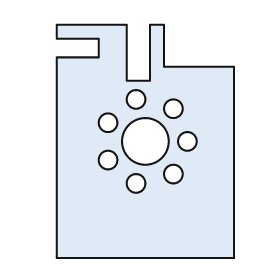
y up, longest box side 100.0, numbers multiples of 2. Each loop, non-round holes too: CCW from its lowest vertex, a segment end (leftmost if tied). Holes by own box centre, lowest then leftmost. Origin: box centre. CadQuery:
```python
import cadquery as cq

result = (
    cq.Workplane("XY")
    .moveTo(-38.0, -50.0)
    .lineTo(38.0, -50.0)
    .lineTo(38.0, 32.0)
    .lineTo(8.0, 32.0)
    .lineTo(8.0, 50.0)
    .lineTo(2.0, 50.0)
    .lineTo(2.0, 26.0)
    .lineTo(-8.0, 26.0)
    .lineTo(-8.0, 50.0)
    .lineTo(-38.0, 50.0)
    .lineTo(-38.0, 44.0)
    .lineTo(-20.0, 44.0)
    .lineTo(-20.0, 36.0)
    .lineTo(-38.0, 36.0)
    .close()
    .moveTo(-4.0, -18.0)
    .circle(4.0)
    .moveTo(12.0, -14.0)
    .circle(4.0)
    .moveTo(-16.0, -8.0)
    .circle(4.0)
    .moveTo(0.0, 0.0)
    .circle(10.0)
    .moveTo(18.0, 0.0)
    .circle(4.0)
    .moveTo(-16.0, 8.0)
    .circle(4.0)
    .moveTo(12.0, 14.0)
    .circle(4.0)
    .moveTo(-4.0, 18.0)
    .circle(4.0)
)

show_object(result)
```